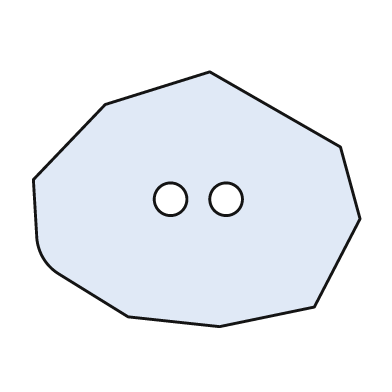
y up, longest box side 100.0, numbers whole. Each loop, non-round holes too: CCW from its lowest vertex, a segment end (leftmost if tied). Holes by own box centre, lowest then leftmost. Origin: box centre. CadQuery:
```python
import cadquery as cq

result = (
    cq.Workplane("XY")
    .moveTo(7.0, -39.0)
    .lineTo(36.0, -33.0)
    .lineTo(50.0, -6.0)
    .lineTo(44.0, 16.0)
    .lineTo(4.0, 39.0)
    .lineTo(-28.0, 29.0)
    .lineTo(-50.0, 6.0)
    .lineTo(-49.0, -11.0)
    .threePointArc((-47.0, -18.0), (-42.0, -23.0))
    .lineTo(-21.0, -36.0)
    .close()
    .moveTo(-8.0, 0.0)
    .circle(5.0)
    .moveTo(9.0, 0.0)
    .circle(5.0)
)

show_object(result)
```